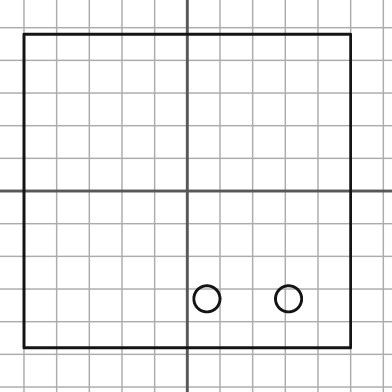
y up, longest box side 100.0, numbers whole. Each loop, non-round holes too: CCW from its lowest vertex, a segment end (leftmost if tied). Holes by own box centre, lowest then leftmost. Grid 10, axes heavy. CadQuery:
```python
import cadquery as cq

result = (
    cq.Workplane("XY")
    .moveTo(-50.0, -48.0)
    .lineTo(50.0, -48.0)
    .lineTo(50.0, 48.0)
    .lineTo(-50.0, 48.0)
    .close()
    .moveTo(6.0, -33.0)
    .circle(4.0)
    .moveTo(31.0, -33.0)
    .circle(4.0)
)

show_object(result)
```